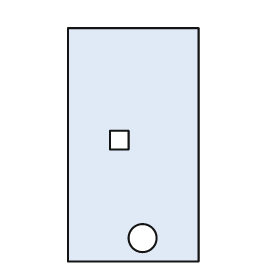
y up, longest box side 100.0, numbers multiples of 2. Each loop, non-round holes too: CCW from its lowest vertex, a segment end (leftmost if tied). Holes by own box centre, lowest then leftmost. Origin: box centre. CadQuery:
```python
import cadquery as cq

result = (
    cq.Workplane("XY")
    .moveTo(-28.0, -50.0)
    .lineTo(28.0, -50.0)
    .lineTo(28.0, 50.0)
    .lineTo(-28.0, 50.0)
    .close()
    .moveTo(4.0, -40.0)
    .circle(6.0)
    .moveTo(-10.0, -2.0)
    .lineTo(-2.0, -2.0)
    .lineTo(-2.0, 6.0)
    .lineTo(-10.0, 6.0)
    .close()
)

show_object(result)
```